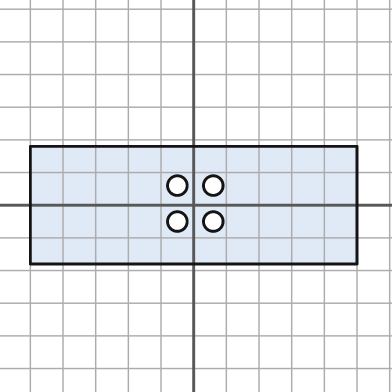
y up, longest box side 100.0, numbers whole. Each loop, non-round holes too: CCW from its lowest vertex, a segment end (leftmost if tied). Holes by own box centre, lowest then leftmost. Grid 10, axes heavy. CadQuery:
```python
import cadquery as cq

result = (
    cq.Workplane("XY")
    .moveTo(-50.0, -18.0)
    .lineTo(50.0, -18.0)
    .lineTo(50.0, 18.0)
    .lineTo(-50.0, 18.0)
    .close()
    .moveTo(-5.0, -5.0)
    .circle(3.0)
    .moveTo(6.0, -5.0)
    .circle(3.0)
    .moveTo(-5.0, 6.0)
    .circle(3.0)
    .moveTo(6.0, 6.0)
    .circle(3.0)
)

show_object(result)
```